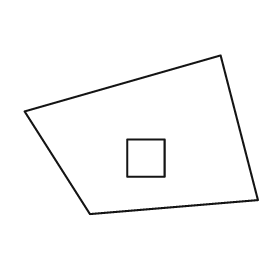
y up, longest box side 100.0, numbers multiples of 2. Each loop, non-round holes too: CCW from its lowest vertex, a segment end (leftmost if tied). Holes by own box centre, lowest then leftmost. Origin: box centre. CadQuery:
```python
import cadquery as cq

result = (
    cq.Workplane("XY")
    .moveTo(-22.0, -34.0)
    .lineTo(50.0, -28.0)
    .lineTo(34.0, 34.0)
    .lineTo(-50.0, 10.0)
    .close()
    .moveTo(-6.0, -18.0)
    .lineTo(10.0, -18.0)
    .lineTo(10.0, -2.0)
    .lineTo(-6.0, -2.0)
    .close()
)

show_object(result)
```